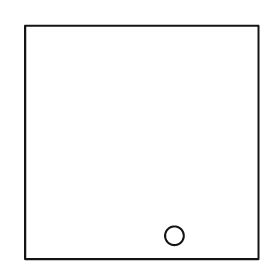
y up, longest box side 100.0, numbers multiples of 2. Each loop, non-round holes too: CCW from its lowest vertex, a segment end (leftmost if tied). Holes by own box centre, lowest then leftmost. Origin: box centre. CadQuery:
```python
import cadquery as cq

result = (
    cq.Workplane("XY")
    .moveTo(-50.0, -50.0)
    .lineTo(50.0, -50.0)
    .lineTo(50.0, 50.0)
    .lineTo(-50.0, 50.0)
    .close()
    .moveTo(14.0, -40.0)
    .circle(4.0)
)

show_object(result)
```